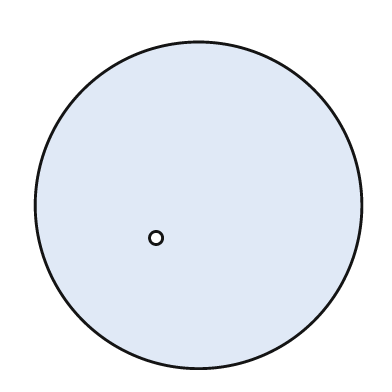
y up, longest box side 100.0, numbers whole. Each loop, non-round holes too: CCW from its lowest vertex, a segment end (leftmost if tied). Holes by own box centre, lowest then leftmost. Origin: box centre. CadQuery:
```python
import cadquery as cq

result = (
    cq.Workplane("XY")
    .moveTo(0.0, 0.0)
    .circle(50.0)
    .moveTo(-13.0, -10.0)
    .circle(2.0)
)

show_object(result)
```